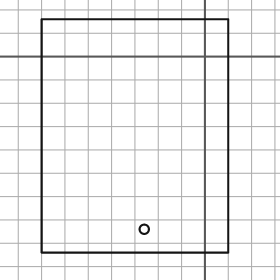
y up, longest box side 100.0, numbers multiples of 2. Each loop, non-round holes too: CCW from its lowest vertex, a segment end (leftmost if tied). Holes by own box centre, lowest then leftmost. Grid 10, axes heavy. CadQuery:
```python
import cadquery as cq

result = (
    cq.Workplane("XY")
    .moveTo(-70.0, -84.0)
    .lineTo(10.0, -84.0)
    .lineTo(10.0, 16.0)
    .lineTo(-70.0, 16.0)
    .close()
    .moveTo(-26.0, -74.0)
    .circle(2.0)
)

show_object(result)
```